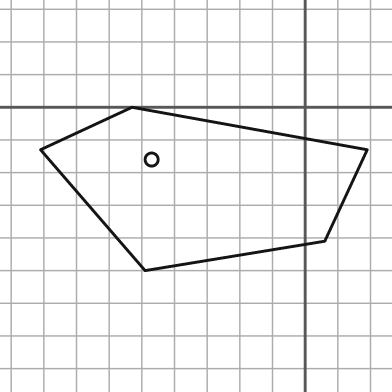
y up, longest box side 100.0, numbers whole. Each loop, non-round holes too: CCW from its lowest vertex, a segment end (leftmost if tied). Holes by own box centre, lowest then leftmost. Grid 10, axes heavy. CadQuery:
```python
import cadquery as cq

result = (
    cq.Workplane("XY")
    .moveTo(-49.0, -50.0)
    .lineTo(6.0, -41.0)
    .lineTo(19.0, -13.0)
    .lineTo(-53.0, 0.0)
    .lineTo(-81.0, -13.0)
    .close()
    .moveTo(-47.0, -16.0)
    .circle(2.0)
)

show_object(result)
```